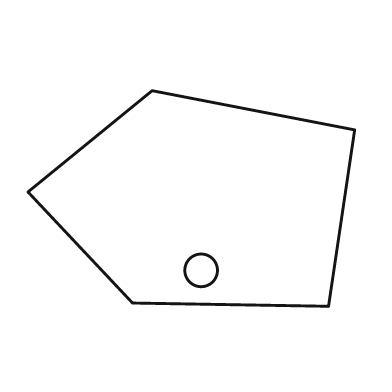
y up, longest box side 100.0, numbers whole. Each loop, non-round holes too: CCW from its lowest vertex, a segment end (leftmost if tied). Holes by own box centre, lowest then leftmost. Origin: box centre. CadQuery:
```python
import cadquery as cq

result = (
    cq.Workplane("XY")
    .moveTo(42.0, -33.0)
    .lineTo(50.0, 21.0)
    .lineTo(-12.0, 33.0)
    .lineTo(-50.0, 2.0)
    .lineTo(-18.0, -32.0)
    .close()
    .moveTo(3.0, -22.0)
    .circle(5.0)
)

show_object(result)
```